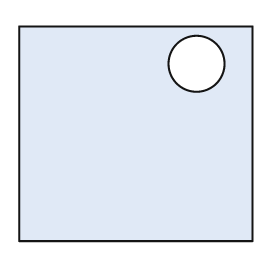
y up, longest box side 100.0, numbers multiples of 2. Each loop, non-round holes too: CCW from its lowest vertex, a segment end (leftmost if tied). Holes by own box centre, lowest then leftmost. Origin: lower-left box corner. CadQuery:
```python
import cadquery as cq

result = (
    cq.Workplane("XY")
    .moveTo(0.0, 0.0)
    .lineTo(100.0, 0.0)
    .lineTo(100.0, 92.0)
    .lineTo(0.0, 92.0)
    .close()
    .moveTo(76.0, 76.0)
    .circle(12.0)
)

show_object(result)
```